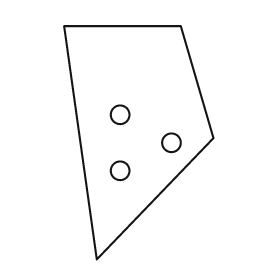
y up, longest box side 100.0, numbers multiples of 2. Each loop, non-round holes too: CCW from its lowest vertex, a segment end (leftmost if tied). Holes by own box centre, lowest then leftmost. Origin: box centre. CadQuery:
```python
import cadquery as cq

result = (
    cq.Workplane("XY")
    .moveTo(-18.0, -50.0)
    .lineTo(32.0, 2.0)
    .lineTo(18.0, 50.0)
    .lineTo(-32.0, 50.0)
    .close()
    .moveTo(-8.0, -12.0)
    .circle(4.0)
    .moveTo(14.0, 0.0)
    .circle(4.0)
    .moveTo(-8.0, 12.0)
    .circle(4.0)
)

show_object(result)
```